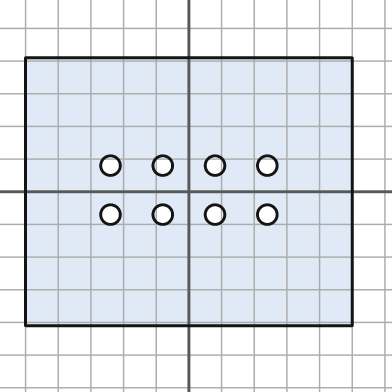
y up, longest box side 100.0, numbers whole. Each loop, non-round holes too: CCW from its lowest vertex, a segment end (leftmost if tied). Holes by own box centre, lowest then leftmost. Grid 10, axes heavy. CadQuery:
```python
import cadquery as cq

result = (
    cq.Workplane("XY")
    .moveTo(-50.0, -41.0)
    .lineTo(50.0, -41.0)
    .lineTo(50.0, 41.0)
    .lineTo(-50.0, 41.0)
    .close()
    .moveTo(-24.0, -7.0)
    .circle(3.0)
    .moveTo(-8.0, -7.0)
    .circle(3.0)
    .moveTo(8.0, -7.0)
    .circle(3.0)
    .moveTo(24.0, -7.0)
    .circle(3.0)
    .moveTo(-24.0, 8.0)
    .circle(3.0)
    .moveTo(-8.0, 8.0)
    .circle(3.0)
    .moveTo(8.0, 8.0)
    .circle(3.0)
    .moveTo(24.0, 8.0)
    .circle(3.0)
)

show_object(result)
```